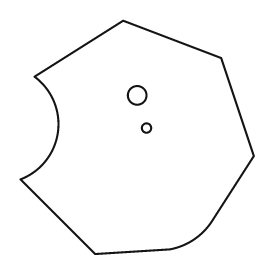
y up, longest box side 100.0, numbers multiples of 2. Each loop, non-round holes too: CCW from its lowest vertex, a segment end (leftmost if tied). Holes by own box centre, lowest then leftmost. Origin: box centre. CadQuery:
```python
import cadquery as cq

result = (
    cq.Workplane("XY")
    .moveTo(-18.0, -50.0)
    .lineTo(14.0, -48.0)
    .threePointArc((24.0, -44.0), (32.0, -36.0))
    .lineTo(50.0, -8.0)
    .lineTo(36.0, 34.0)
    .lineTo(-6.0, 50.0)
    .lineTo(-44.0, 26.0)
    .threePointArc((-34.0, 2.0), (-50.0, -18.0))
    .close()
    .moveTo(4.0, 4.0)
    .circle(2.0)
    .moveTo(0.0, 18.0)
    .circle(4.0)
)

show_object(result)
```